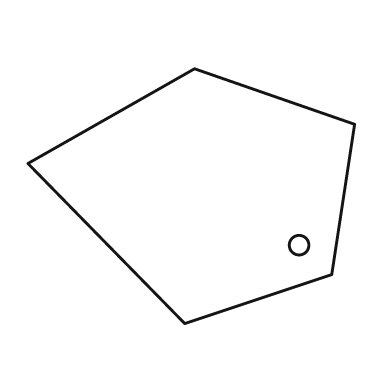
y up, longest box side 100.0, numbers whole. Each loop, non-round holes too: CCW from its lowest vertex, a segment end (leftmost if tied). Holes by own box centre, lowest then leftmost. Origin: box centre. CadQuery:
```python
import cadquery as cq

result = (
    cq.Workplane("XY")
    .moveTo(-2.0, -39.0)
    .lineTo(43.0, -24.0)
    .lineTo(50.0, 22.0)
    .lineTo(1.0, 39.0)
    .lineTo(-50.0, 10.0)
    .close()
    .moveTo(33.0, -15.0)
    .circle(3.0)
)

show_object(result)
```